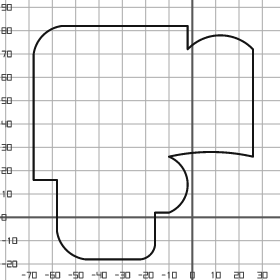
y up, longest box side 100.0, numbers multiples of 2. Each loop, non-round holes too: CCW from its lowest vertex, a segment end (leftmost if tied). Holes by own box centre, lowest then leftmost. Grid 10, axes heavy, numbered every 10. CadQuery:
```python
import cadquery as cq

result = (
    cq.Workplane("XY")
    .moveTo(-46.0, -18.0)
    .lineTo(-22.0, -18.0)
    .threePointArc((-18.0, -16.0), (-16.0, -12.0))
    .lineTo(-16.0, 2.0)
    .lineTo(-10.0, 2.0)
    .threePointArc((-2.0, 14.0), (-10.0, 26.0))
    .threePointArc((8.0, 28.0), (26.0, 26.0))
    .lineTo(26.0, 72.0)
    .threePointArc((12.0, 78.0), (-2.0, 72.0))
    .lineTo(-2.0, 82.0)
    .lineTo(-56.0, 82.0)
    .threePointArc((-64.0, 78.0), (-68.0, 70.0))
    .lineTo(-68.0, 16.0)
    .lineTo(-58.0, 16.0)
    .lineTo(-58.0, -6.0)
    .threePointArc((-54.0, -14.0), (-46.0, -18.0))
    .close()
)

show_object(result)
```